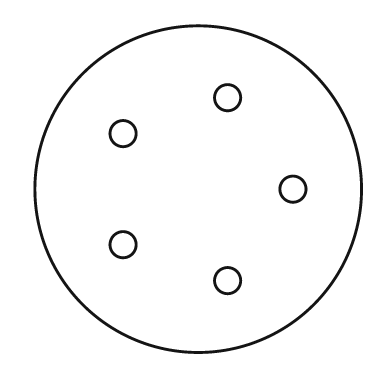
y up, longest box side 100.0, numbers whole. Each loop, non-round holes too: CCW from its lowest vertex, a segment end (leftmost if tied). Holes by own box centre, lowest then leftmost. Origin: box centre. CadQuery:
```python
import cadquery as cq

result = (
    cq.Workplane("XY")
    .moveTo(0.0, 0.0)
    .circle(50.0)
    .moveTo(9.0, -28.0)
    .circle(4.0)
    .moveTo(-23.0, -17.0)
    .circle(4.0)
    .moveTo(29.0, 0.0)
    .circle(4.0)
    .moveTo(-23.0, 17.0)
    .circle(4.0)
    .moveTo(9.0, 28.0)
    .circle(4.0)
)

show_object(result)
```